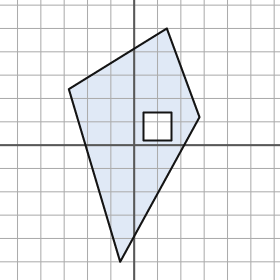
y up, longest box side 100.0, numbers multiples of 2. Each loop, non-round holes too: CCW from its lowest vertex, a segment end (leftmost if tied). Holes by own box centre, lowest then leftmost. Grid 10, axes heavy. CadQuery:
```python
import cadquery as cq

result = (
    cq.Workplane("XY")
    .moveTo(-6.0, -50.0)
    .lineTo(28.0, 12.0)
    .lineTo(14.0, 50.0)
    .lineTo(-28.0, 24.0)
    .close()
    .moveTo(4.0, 2.0)
    .lineTo(16.0, 2.0)
    .lineTo(16.0, 14.0)
    .lineTo(4.0, 14.0)
    .close()
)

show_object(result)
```